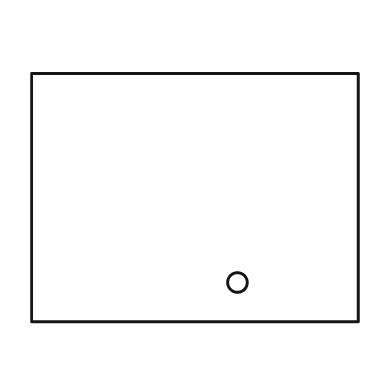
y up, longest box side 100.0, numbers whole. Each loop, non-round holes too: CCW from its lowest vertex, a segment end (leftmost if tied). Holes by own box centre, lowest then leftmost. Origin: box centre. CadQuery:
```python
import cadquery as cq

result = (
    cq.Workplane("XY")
    .moveTo(-50.0, -38.0)
    .lineTo(50.0, -38.0)
    .lineTo(50.0, 38.0)
    .lineTo(-50.0, 38.0)
    .close()
    .moveTo(13.0, -26.0)
    .circle(3.0)
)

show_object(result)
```